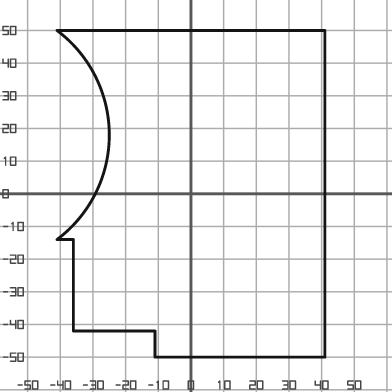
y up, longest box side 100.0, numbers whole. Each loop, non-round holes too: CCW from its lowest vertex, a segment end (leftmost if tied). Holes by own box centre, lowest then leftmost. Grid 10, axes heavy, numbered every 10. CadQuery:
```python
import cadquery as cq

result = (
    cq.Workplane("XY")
    .moveTo(-11.0, -50.0)
    .lineTo(41.0, -50.0)
    .lineTo(41.0, 50.0)
    .lineTo(-41.0, 50.0)
    .threePointArc((-25.0, 18.0), (-41.0, -14.0))
    .lineTo(-36.0, -14.0)
    .lineTo(-36.0, -42.0)
    .lineTo(-11.0, -42.0)
    .close()
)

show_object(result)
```